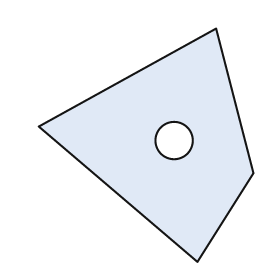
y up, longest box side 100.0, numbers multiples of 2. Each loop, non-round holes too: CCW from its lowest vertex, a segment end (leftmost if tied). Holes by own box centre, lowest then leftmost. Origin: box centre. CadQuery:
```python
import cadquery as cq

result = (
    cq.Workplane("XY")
    .moveTo(22.0, -50.0)
    .lineTo(46.0, -12.0)
    .lineTo(30.0, 50.0)
    .lineTo(-46.0, 8.0)
    .close()
    .moveTo(12.0, 2.0)
    .circle(8.0)
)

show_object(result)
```